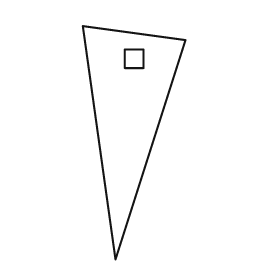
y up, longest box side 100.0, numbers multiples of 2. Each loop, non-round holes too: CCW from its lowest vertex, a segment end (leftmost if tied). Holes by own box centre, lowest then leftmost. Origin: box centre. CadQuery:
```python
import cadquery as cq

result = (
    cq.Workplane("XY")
    .moveTo(-8.0, -50.0)
    .lineTo(22.0, 44.0)
    .lineTo(-22.0, 50.0)
    .close()
    .moveTo(-4.0, 32.0)
    .lineTo(4.0, 32.0)
    .lineTo(4.0, 40.0)
    .lineTo(-4.0, 40.0)
    .close()
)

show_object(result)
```